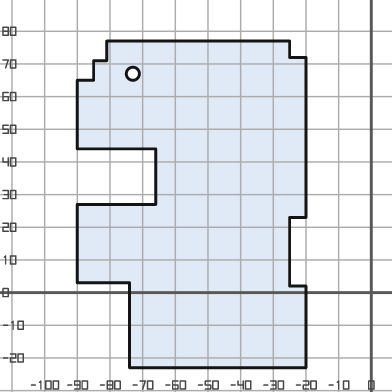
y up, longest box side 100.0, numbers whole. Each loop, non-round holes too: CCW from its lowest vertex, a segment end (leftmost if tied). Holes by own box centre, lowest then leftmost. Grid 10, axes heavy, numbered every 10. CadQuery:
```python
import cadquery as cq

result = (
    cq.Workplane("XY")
    .moveTo(-74.0, -23.0)
    .lineTo(-20.0, -23.0)
    .lineTo(-20.0, 2.0)
    .lineTo(-25.0, 2.0)
    .lineTo(-25.0, 23.0)
    .lineTo(-20.0, 23.0)
    .lineTo(-20.0, 72.0)
    .lineTo(-25.0, 72.0)
    .lineTo(-25.0, 77.0)
    .lineTo(-81.0, 77.0)
    .lineTo(-81.0, 71.0)
    .lineTo(-85.0, 71.0)
    .lineTo(-85.0, 65.0)
    .lineTo(-90.0, 65.0)
    .lineTo(-90.0, 44.0)
    .lineTo(-66.0, 44.0)
    .lineTo(-66.0, 27.0)
    .lineTo(-90.0, 27.0)
    .lineTo(-90.0, 3.0)
    .lineTo(-74.0, 3.0)
    .close()
    .moveTo(-73.0, 67.0)
    .circle(2.0)
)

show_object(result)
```